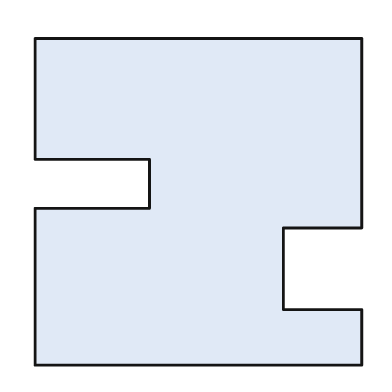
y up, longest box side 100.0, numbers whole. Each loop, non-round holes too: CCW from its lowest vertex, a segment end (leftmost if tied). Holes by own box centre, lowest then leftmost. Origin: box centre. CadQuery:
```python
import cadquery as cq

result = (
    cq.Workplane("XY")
    .moveTo(-50.0, -50.0)
    .lineTo(50.0, -50.0)
    .lineTo(50.0, -33.0)
    .lineTo(26.0, -33.0)
    .lineTo(26.0, -8.0)
    .lineTo(50.0, -8.0)
    .lineTo(50.0, 50.0)
    .lineTo(-50.0, 50.0)
    .lineTo(-50.0, 13.0)
    .lineTo(-15.0, 13.0)
    .lineTo(-15.0, -2.0)
    .lineTo(-50.0, -2.0)
    .close()
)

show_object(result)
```